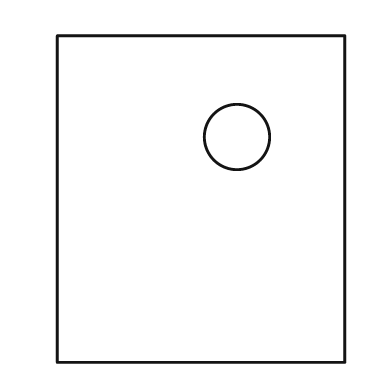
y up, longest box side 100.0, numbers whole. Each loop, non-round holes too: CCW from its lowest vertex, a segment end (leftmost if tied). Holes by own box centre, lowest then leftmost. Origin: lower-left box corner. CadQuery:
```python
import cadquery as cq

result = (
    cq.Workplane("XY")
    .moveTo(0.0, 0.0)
    .lineTo(88.0, 0.0)
    .lineTo(88.0, 100.0)
    .lineTo(0.0, 100.0)
    .close()
    .moveTo(55.0, 69.0)
    .circle(10.0)
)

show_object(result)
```